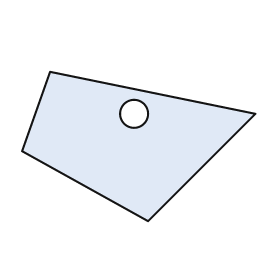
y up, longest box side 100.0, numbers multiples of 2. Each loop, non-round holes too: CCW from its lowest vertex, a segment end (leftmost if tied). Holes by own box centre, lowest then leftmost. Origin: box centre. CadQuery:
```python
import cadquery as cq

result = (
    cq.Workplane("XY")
    .moveTo(4.0, -32.0)
    .lineTo(50.0, 14.0)
    .lineTo(-38.0, 32.0)
    .lineTo(-50.0, -2.0)
    .close()
    .moveTo(-2.0, 14.0)
    .circle(6.0)
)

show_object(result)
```